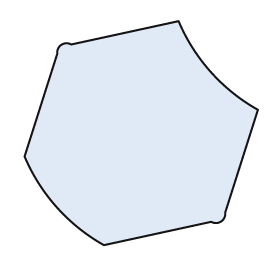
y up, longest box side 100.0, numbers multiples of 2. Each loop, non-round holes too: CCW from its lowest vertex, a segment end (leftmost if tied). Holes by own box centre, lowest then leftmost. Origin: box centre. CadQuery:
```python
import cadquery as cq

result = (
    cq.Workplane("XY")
    .moveTo(-16.0, -48.0)
    .lineTo(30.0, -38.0)
    .threePointArc((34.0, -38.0), (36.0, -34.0))
    .lineTo(50.0, 10.0)
    .threePointArc((30.0, 26.0), (16.0, 48.0))
    .lineTo(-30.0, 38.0)
    .threePointArc((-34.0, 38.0), (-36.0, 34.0))
    .lineTo(-50.0, -10.0)
    .threePointArc((-36.0, -32.0), (-16.0, -48.0))
    .close()
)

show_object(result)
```